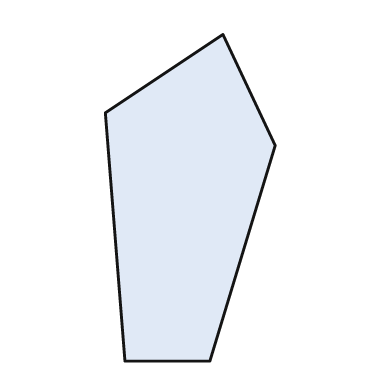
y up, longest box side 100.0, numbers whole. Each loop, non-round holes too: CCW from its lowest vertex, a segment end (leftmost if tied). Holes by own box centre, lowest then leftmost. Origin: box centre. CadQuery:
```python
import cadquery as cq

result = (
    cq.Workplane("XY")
    .moveTo(-20.0, -50.0)
    .lineTo(6.0, -50.0)
    .lineTo(26.0, 16.0)
    .lineTo(10.0, 50.0)
    .lineTo(-26.0, 26.0)
    .close()
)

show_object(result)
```